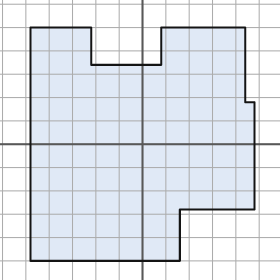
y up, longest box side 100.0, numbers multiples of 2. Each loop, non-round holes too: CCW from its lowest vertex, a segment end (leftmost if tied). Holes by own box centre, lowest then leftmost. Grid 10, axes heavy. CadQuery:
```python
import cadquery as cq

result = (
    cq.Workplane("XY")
    .moveTo(-48.0, -50.0)
    .lineTo(16.0, -50.0)
    .lineTo(16.0, -28.0)
    .lineTo(48.0, -28.0)
    .lineTo(48.0, 18.0)
    .lineTo(44.0, 18.0)
    .lineTo(44.0, 50.0)
    .lineTo(8.0, 50.0)
    .lineTo(8.0, 34.0)
    .lineTo(-22.0, 34.0)
    .lineTo(-22.0, 50.0)
    .lineTo(-48.0, 50.0)
    .close()
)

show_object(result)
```